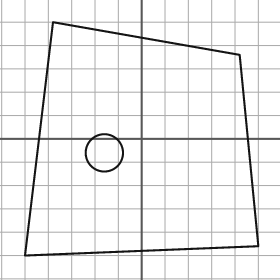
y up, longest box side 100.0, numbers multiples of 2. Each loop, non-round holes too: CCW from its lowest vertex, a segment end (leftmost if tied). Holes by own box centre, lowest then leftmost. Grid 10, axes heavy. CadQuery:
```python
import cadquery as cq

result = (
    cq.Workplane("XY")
    .moveTo(-50.0, -50.0)
    .lineTo(50.0, -46.0)
    .lineTo(42.0, 36.0)
    .lineTo(-38.0, 50.0)
    .close()
    .moveTo(-16.0, -6.0)
    .circle(8.0)
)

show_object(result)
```